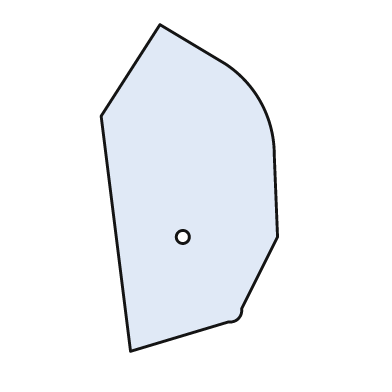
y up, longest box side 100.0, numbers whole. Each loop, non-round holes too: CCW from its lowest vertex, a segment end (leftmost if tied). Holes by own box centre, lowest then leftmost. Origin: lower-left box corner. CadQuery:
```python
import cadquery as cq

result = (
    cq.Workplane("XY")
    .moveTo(9.0, 0.0)
    .lineTo(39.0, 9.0)
    .threePointArc((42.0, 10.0), (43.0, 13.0))
    .lineTo(54.0, 35.0)
    .lineTo(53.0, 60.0)
    .threePointArc((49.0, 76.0), (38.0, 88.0))
    .lineTo(18.0, 100.0)
    .lineTo(0.0, 72.0)
    .close()
    .moveTo(25.0, 35.0)
    .circle(2.0)
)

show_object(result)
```